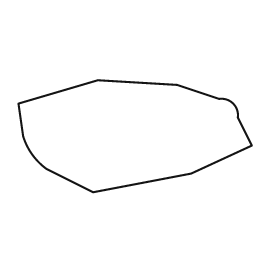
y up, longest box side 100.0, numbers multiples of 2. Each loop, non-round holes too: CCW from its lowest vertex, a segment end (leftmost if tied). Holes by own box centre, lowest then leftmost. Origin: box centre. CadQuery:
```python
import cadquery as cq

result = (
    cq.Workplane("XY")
    .moveTo(-18.0, -24.0)
    .lineTo(24.0, -16.0)
    .lineTo(50.0, -4.0)
    .lineTo(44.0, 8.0)
    .threePointArc((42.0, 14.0), (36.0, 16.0))
    .lineTo(18.0, 22.0)
    .lineTo(-16.0, 24.0)
    .lineTo(-50.0, 14.0)
    .lineTo(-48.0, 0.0)
    .threePointArc((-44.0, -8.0), (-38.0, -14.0))
    .close()
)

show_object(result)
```